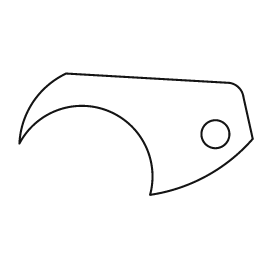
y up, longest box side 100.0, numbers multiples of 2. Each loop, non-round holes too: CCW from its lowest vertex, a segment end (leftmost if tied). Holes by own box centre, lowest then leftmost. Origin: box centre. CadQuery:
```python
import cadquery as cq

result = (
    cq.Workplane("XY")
    .moveTo(6.0, -26.0)
    .threePointArc((30.0, -18.0), (50.0, -2.0))
    .lineTo(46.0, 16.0)
    .threePointArc((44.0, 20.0), (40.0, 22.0))
    .lineTo(-30.0, 26.0)
    .threePointArc((-44.0, 14.0), (-50.0, -4.0))
    .threePointArc((-12.0, 10.0), (6.0, -26.0))
    .close()
    .moveTo(34.0, 0.0)
    .circle(6.0)
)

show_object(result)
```